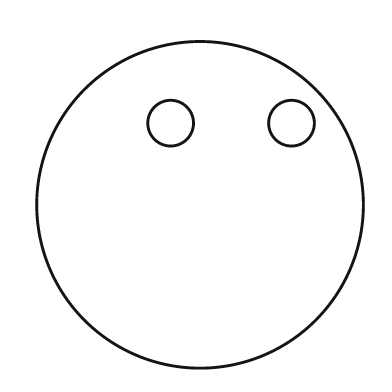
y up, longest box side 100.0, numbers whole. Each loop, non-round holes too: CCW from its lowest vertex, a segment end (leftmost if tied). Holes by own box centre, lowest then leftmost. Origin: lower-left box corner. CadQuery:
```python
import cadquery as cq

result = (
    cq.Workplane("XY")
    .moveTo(50.0, 50.0)
    .circle(50.0)
    .moveTo(41.0, 75.0)
    .circle(7.0)
    .moveTo(78.0, 75.0)
    .circle(7.0)
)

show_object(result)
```